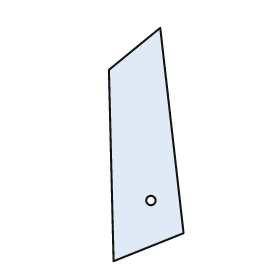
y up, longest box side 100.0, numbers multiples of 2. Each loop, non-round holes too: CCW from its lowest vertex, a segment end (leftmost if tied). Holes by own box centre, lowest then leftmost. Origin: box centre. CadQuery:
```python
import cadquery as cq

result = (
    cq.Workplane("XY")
    .moveTo(-14.0, -50.0)
    .lineTo(16.0, -38.0)
    .lineTo(6.0, 50.0)
    .lineTo(-16.0, 32.0)
    .close()
    .moveTo(2.0, -24.0)
    .circle(2.0)
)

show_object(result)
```